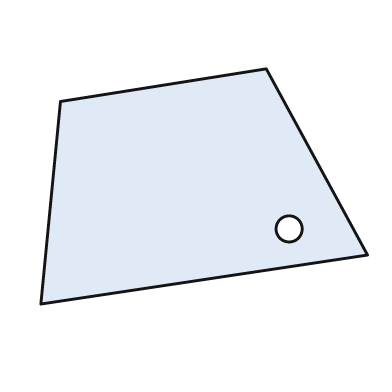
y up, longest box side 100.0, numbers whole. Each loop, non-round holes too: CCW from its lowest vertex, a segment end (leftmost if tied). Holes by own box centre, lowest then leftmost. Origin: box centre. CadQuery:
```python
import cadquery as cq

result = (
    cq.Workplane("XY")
    .moveTo(-50.0, -36.0)
    .lineTo(50.0, -21.0)
    .lineTo(19.0, 36.0)
    .lineTo(-44.0, 26.0)
    .close()
    .moveTo(26.0, -13.0)
    .circle(4.0)
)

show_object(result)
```